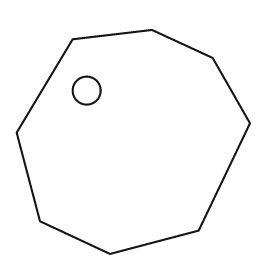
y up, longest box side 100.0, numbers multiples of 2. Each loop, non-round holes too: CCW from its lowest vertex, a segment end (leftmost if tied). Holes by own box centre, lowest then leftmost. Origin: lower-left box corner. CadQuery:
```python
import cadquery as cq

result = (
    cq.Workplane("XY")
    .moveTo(40.0, 0.0)
    .lineTo(78.0, 10.0)
    .lineTo(100.0, 56.0)
    .lineTo(84.0, 84.0)
    .lineTo(58.0, 96.0)
    .lineTo(24.0, 92.0)
    .lineTo(0.0, 52.0)
    .lineTo(10.0, 14.0)
    .close()
    .moveTo(30.0, 70.0)
    .circle(6.0)
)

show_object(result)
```